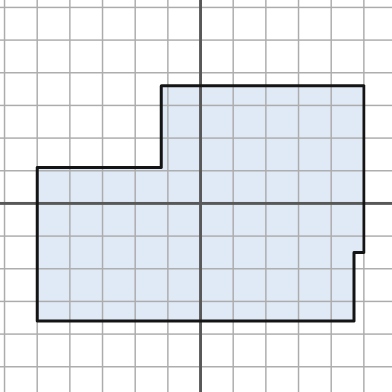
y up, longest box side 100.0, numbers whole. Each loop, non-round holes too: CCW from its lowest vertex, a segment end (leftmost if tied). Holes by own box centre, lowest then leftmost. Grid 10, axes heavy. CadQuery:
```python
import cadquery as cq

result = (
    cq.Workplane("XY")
    .moveTo(-50.0, -36.0)
    .lineTo(47.0, -36.0)
    .lineTo(47.0, -15.0)
    .lineTo(50.0, -15.0)
    .lineTo(50.0, 36.0)
    .lineTo(-12.0, 36.0)
    .lineTo(-12.0, 11.0)
    .lineTo(-50.0, 11.0)
    .close()
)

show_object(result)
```